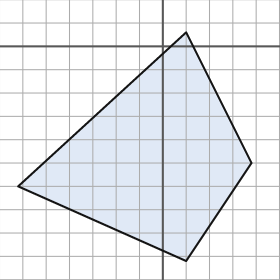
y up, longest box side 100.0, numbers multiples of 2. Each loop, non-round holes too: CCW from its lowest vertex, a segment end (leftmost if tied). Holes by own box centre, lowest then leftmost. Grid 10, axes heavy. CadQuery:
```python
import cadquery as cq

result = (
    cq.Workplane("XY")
    .moveTo(10.0, -92.0)
    .lineTo(38.0, -50.0)
    .lineTo(10.0, 6.0)
    .lineTo(-62.0, -60.0)
    .close()
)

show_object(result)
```